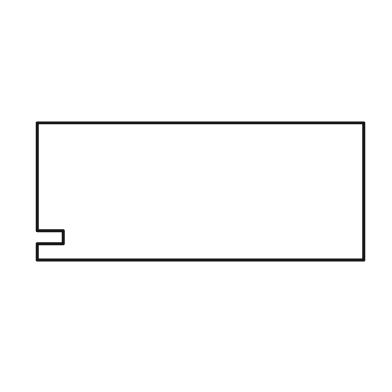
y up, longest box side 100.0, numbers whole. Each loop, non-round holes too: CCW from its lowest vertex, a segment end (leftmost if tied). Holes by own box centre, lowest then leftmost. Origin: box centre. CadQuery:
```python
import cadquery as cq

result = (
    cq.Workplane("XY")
    .moveTo(-50.0, -21.0)
    .lineTo(50.0, -21.0)
    .lineTo(50.0, 21.0)
    .lineTo(-50.0, 21.0)
    .lineTo(-50.0, -12.0)
    .lineTo(-42.0, -12.0)
    .lineTo(-42.0, -16.0)
    .lineTo(-50.0, -16.0)
    .close()
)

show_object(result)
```